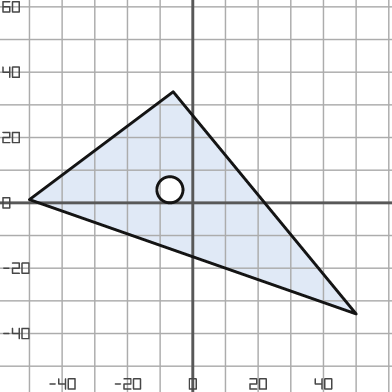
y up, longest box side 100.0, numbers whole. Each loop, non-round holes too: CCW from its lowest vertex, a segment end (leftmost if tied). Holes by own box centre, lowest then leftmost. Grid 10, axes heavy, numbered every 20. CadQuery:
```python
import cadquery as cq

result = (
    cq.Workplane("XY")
    .moveTo(50.0, -34.0)
    .lineTo(-6.0, 34.0)
    .lineTo(-50.0, 1.0)
    .close()
    .moveTo(-7.0, 4.0)
    .circle(4.0)
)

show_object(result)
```